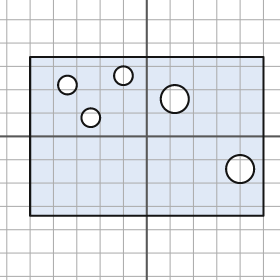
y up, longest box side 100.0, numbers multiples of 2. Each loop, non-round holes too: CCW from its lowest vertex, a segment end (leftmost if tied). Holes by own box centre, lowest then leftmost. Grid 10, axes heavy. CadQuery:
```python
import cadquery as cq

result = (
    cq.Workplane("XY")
    .moveTo(-50.0, -34.0)
    .lineTo(50.0, -34.0)
    .lineTo(50.0, 34.0)
    .lineTo(-50.0, 34.0)
    .close()
    .moveTo(40.0, -14.0)
    .circle(6.0)
    .moveTo(-24.0, 8.0)
    .circle(4.0)
    .moveTo(12.0, 16.0)
    .circle(6.0)
    .moveTo(-34.0, 22.0)
    .circle(4.0)
    .moveTo(-10.0, 26.0)
    .circle(4.0)
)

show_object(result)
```